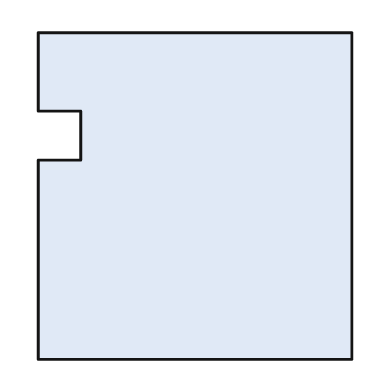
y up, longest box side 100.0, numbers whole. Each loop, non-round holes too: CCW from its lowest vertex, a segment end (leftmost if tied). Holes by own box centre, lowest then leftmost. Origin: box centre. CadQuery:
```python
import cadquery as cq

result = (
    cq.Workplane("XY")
    .moveTo(-48.0, -50.0)
    .lineTo(48.0, -50.0)
    .lineTo(48.0, 50.0)
    .lineTo(-48.0, 50.0)
    .lineTo(-48.0, 26.0)
    .lineTo(-35.0, 26.0)
    .lineTo(-35.0, 11.0)
    .lineTo(-48.0, 11.0)
    .close()
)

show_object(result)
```